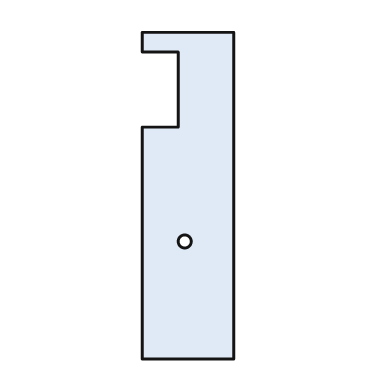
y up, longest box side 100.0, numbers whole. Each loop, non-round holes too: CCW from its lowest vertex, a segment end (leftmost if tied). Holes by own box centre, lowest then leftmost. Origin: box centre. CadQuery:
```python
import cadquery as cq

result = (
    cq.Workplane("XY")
    .moveTo(-14.0, -50.0)
    .lineTo(14.0, -50.0)
    .lineTo(14.0, 50.0)
    .lineTo(-14.0, 50.0)
    .lineTo(-14.0, 44.0)
    .lineTo(-3.0, 44.0)
    .lineTo(-3.0, 21.0)
    .lineTo(-14.0, 21.0)
    .close()
    .moveTo(-1.0, -14.0)
    .circle(2.0)
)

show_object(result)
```